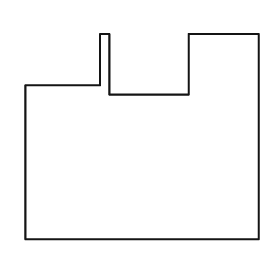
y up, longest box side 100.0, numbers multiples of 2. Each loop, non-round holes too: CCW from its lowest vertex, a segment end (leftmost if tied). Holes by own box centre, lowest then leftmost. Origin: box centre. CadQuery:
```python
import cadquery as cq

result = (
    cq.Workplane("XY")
    .moveTo(-50.0, -44.0)
    .lineTo(50.0, -44.0)
    .lineTo(50.0, 44.0)
    .lineTo(20.0, 44.0)
    .lineTo(20.0, 18.0)
    .lineTo(-14.0, 18.0)
    .lineTo(-14.0, 44.0)
    .lineTo(-18.0, 44.0)
    .lineTo(-18.0, 22.0)
    .lineTo(-50.0, 22.0)
    .close()
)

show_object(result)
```